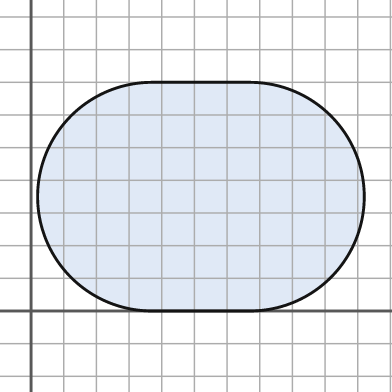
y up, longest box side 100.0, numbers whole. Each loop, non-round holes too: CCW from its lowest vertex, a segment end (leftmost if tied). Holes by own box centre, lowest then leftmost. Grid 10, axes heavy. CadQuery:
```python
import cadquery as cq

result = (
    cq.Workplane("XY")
    .moveTo(37.0, 0.0)
    .lineTo(67.0, 0.0)
    .threePointArc((102.0, 35.0), (67.0, 70.0))
    .lineTo(37.0, 70.0)
    .threePointArc((2.0, 35.0), (37.0, 0.0))
    .close()
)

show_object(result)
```